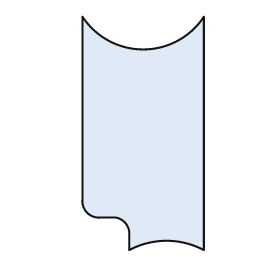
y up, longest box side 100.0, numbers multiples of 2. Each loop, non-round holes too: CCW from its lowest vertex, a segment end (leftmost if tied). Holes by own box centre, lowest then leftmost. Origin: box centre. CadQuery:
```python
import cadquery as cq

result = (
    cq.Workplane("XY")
    .moveTo(-6.0, -50.0)
    .threePointArc((10.0, -46.0), (26.0, -50.0))
    .lineTo(26.0, 50.0)
    .threePointArc((0.0, 36.0), (-26.0, 50.0))
    .lineTo(-26.0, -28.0)
    .threePointArc((-24.0, -34.0), (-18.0, -36.0))
    .lineTo(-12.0, -36.0)
    .threePointArc((-8.0, -38.0), (-6.0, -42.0))
    .close()
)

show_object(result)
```